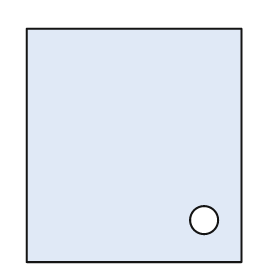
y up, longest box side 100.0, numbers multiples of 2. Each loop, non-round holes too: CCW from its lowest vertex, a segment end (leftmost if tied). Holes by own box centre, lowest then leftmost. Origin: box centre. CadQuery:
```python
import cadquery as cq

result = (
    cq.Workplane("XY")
    .moveTo(-46.0, -50.0)
    .lineTo(46.0, -50.0)
    .lineTo(46.0, 50.0)
    .lineTo(-46.0, 50.0)
    .close()
    .moveTo(30.0, -32.0)
    .circle(6.0)
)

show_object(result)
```